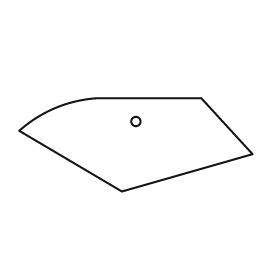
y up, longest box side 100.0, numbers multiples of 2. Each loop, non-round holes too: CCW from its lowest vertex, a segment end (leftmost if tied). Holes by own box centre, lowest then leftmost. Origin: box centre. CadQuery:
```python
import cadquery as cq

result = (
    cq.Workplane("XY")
    .moveTo(-6.0, -20.0)
    .lineTo(50.0, -4.0)
    .lineTo(28.0, 20.0)
    .lineTo(-16.0, 20.0)
    .threePointArc((-34.0, 16.0), (-50.0, 6.0))
    .close()
    .moveTo(0.0, 10.0)
    .circle(2.0)
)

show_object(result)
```